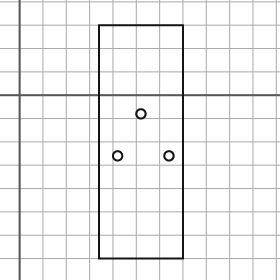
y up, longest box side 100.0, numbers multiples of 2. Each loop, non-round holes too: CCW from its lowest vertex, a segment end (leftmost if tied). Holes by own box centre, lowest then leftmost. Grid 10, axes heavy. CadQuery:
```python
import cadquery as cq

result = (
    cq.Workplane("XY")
    .moveTo(34.0, -70.0)
    .lineTo(70.0, -70.0)
    .lineTo(70.0, 30.0)
    .lineTo(34.0, 30.0)
    .close()
    .moveTo(42.0, -26.0)
    .circle(2.0)
    .moveTo(64.0, -26.0)
    .circle(2.0)
    .moveTo(52.0, -8.0)
    .circle(2.0)
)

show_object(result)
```